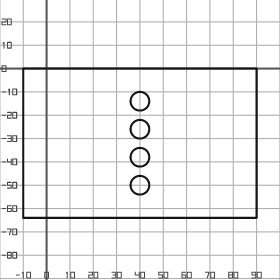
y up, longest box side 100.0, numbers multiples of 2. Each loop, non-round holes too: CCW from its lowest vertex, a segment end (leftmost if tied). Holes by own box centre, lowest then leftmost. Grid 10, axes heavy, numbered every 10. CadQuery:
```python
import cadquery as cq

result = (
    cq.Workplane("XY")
    .moveTo(-10.0, -64.0)
    .lineTo(90.0, -64.0)
    .lineTo(90.0, 0.0)
    .lineTo(-10.0, 0.0)
    .close()
    .moveTo(40.0, -50.0)
    .circle(4.0)
    .moveTo(40.0, -38.0)
    .circle(4.0)
    .moveTo(40.0, -26.0)
    .circle(4.0)
    .moveTo(40.0, -14.0)
    .circle(4.0)
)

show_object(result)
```